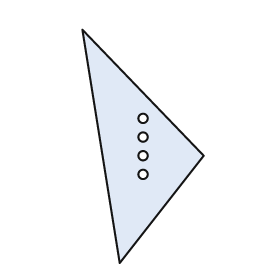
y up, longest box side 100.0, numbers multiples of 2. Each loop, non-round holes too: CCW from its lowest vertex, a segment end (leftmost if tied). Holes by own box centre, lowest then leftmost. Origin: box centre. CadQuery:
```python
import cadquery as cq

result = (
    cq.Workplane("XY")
    .moveTo(-10.0, -50.0)
    .lineTo(26.0, -4.0)
    .lineTo(-26.0, 50.0)
    .close()
    .moveTo(0.0, -12.0)
    .circle(2.0)
    .moveTo(0.0, -4.0)
    .circle(2.0)
    .moveTo(0.0, 4.0)
    .circle(2.0)
    .moveTo(0.0, 12.0)
    .circle(2.0)
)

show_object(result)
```